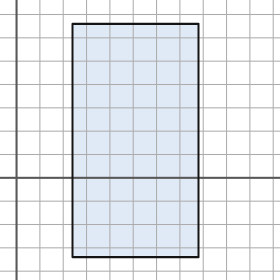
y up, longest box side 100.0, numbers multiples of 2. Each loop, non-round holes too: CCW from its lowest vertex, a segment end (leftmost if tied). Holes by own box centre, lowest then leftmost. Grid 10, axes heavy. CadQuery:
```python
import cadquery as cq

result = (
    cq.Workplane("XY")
    .moveTo(24.0, -34.0)
    .lineTo(78.0, -34.0)
    .lineTo(78.0, 66.0)
    .lineTo(24.0, 66.0)
    .close()
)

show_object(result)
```